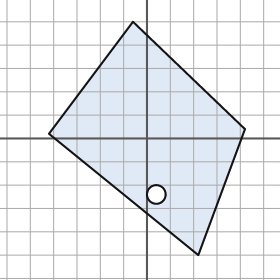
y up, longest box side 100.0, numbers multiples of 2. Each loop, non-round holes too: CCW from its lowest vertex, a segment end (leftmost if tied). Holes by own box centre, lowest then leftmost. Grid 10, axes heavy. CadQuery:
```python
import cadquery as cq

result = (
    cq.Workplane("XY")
    .moveTo(22.0, -50.0)
    .lineTo(42.0, 4.0)
    .lineTo(-6.0, 50.0)
    .lineTo(-42.0, 2.0)
    .close()
    .moveTo(4.0, -24.0)
    .circle(4.0)
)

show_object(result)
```